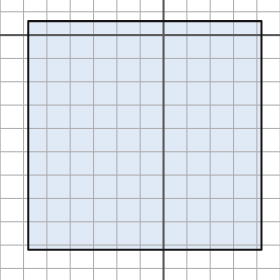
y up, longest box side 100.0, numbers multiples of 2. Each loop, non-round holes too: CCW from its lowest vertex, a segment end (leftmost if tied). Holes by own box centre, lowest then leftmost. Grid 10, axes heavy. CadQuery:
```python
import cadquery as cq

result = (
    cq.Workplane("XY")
    .moveTo(-58.0, -92.0)
    .lineTo(42.0, -92.0)
    .lineTo(42.0, 6.0)
    .lineTo(-58.0, 6.0)
    .close()
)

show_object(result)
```